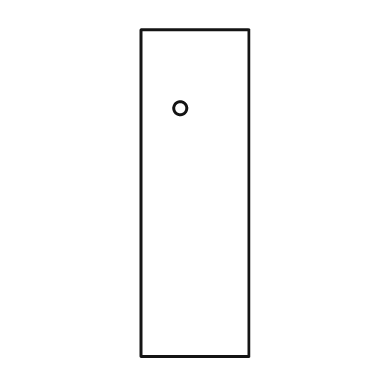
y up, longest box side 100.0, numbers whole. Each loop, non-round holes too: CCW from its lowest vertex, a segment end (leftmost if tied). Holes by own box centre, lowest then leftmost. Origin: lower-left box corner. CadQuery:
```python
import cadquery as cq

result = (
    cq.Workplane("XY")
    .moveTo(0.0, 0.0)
    .lineTo(33.0, 0.0)
    .lineTo(33.0, 100.0)
    .lineTo(0.0, 100.0)
    .close()
    .moveTo(12.0, 76.0)
    .circle(2.0)
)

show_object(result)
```